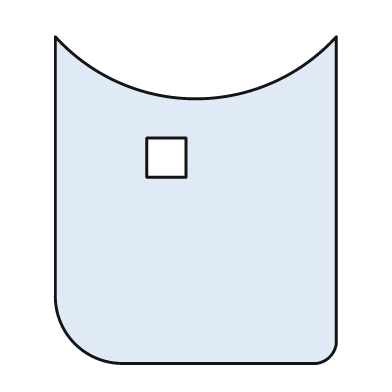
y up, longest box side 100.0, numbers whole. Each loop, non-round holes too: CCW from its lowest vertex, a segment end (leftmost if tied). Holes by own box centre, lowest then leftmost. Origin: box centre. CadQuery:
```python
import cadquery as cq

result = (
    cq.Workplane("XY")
    .moveTo(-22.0, -50.0)
    .lineTo(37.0, -50.0)
    .threePointArc((41.0, -48.0), (43.0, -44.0))
    .lineTo(43.0, 50.0)
    .threePointArc((0.0, 31.0), (-43.0, 50.0))
    .lineTo(-43.0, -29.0)
    .threePointArc((-37.0, -44.0), (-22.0, -50.0))
    .close()
    .moveTo(-15.0, 7.0)
    .lineTo(-3.0, 7.0)
    .lineTo(-3.0, 19.0)
    .lineTo(-15.0, 19.0)
    .close()
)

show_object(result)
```